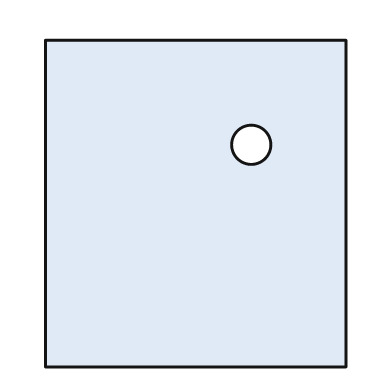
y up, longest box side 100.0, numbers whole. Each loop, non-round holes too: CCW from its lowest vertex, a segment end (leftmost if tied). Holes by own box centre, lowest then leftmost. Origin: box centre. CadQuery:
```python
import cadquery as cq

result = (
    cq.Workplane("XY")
    .moveTo(-46.0, -50.0)
    .lineTo(46.0, -50.0)
    .lineTo(46.0, 50.0)
    .lineTo(-46.0, 50.0)
    .close()
    .moveTo(17.0, 18.0)
    .circle(6.0)
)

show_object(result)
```